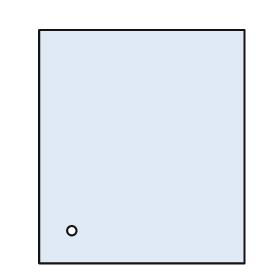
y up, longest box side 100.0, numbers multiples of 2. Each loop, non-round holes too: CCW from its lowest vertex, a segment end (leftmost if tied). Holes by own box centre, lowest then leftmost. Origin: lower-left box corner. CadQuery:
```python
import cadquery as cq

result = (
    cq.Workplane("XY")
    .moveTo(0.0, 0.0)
    .lineTo(88.0, 0.0)
    .lineTo(88.0, 100.0)
    .lineTo(0.0, 100.0)
    .close()
    .moveTo(14.0, 14.0)
    .circle(2.0)
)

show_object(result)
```